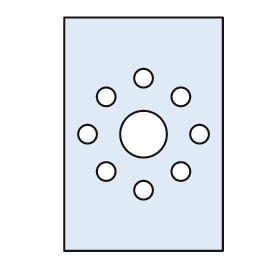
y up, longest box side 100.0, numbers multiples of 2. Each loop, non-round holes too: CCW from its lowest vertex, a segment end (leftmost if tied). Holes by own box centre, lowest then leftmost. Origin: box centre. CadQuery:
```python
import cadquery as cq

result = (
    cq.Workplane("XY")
    .moveTo(-34.0, -50.0)
    .lineTo(34.0, -50.0)
    .lineTo(34.0, 50.0)
    .lineTo(-34.0, 50.0)
    .close()
    .moveTo(0.0, -24.0)
    .circle(4.0)
    .moveTo(-16.0, -16.0)
    .circle(4.0)
    .moveTo(16.0, -16.0)
    .circle(4.0)
    .moveTo(-24.0, 0.0)
    .circle(4.0)
    .moveTo(0.0, 0.0)
    .circle(10.0)
    .moveTo(24.0, 0.0)
    .circle(4.0)
    .moveTo(-16.0, 16.0)
    .circle(4.0)
    .moveTo(16.0, 16.0)
    .circle(4.0)
    .moveTo(0.0, 24.0)
    .circle(4.0)
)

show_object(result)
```